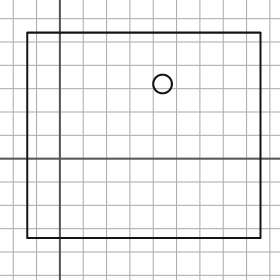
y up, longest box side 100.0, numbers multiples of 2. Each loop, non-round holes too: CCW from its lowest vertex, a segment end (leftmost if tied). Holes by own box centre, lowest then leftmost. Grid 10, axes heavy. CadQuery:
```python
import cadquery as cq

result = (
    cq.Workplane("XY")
    .moveTo(-14.0, -34.0)
    .lineTo(86.0, -34.0)
    .lineTo(86.0, 54.0)
    .lineTo(-14.0, 54.0)
    .close()
    .moveTo(44.0, 32.0)
    .circle(4.0)
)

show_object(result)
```